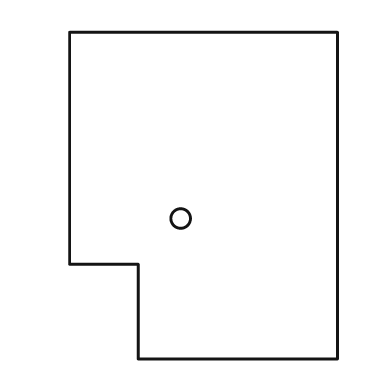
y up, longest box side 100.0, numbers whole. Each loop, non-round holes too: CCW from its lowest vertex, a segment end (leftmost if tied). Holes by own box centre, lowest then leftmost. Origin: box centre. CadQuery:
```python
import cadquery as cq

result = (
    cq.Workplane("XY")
    .moveTo(-20.0, -50.0)
    .lineTo(41.0, -50.0)
    .lineTo(41.0, 50.0)
    .lineTo(-41.0, 50.0)
    .lineTo(-41.0, -21.0)
    .lineTo(-20.0, -21.0)
    .close()
    .moveTo(-7.0, -7.0)
    .circle(3.0)
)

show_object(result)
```